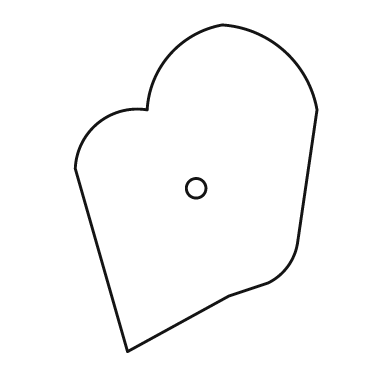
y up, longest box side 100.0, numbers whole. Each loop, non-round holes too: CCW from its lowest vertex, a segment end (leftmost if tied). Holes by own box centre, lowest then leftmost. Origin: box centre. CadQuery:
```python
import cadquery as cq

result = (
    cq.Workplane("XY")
    .moveTo(-21.0, -50.0)
    .lineTo(10.0, -33.0)
    .lineTo(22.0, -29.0)
    .threePointArc((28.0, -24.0), (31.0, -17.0))
    .lineTo(37.0, 24.0)
    .threePointArc((27.0, 42.0), (8.0, 50.0))
    .threePointArc((-8.0, 41.0), (-15.0, 24.0))
    .threePointArc((-30.0, 20.0), (-37.0, 6.0))
    .close()
    .moveTo(0.0, 0.0)
    .circle(3.0)
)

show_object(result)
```